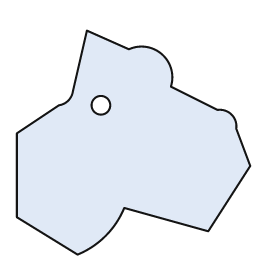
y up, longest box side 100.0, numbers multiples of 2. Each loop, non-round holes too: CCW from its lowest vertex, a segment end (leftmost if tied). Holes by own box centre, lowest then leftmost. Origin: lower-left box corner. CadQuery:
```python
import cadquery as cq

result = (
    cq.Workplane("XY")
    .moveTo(26.0, 0.0)
    .threePointArc((38.0, 8.0), (46.0, 20.0))
    .lineTo(82.0, 10.0)
    .lineTo(100.0, 38.0)
    .lineTo(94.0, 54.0)
    .threePointArc((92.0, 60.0), (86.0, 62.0))
    .lineTo(66.0, 72.0)
    .threePointArc((62.0, 86.0), (48.0, 88.0))
    .lineTo(30.0, 96.0)
    .lineTo(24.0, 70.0)
    .threePointArc((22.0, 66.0), (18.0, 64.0))
    .lineTo(0.0, 52.0)
    .lineTo(0.0, 16.0)
    .close()
    .moveTo(36.0, 64.0)
    .circle(4.0)
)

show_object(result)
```